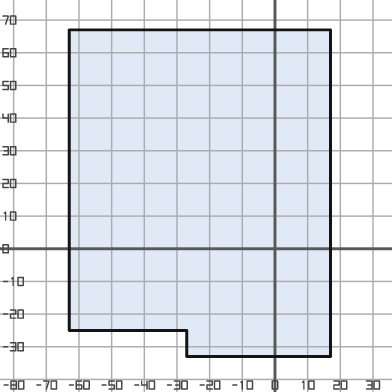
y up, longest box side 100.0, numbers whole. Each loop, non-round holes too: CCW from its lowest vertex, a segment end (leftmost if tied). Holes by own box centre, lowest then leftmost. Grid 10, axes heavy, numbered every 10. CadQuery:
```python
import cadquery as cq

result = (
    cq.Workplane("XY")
    .moveTo(-27.0, -33.0)
    .lineTo(17.0, -33.0)
    .lineTo(17.0, 67.0)
    .lineTo(-63.0, 67.0)
    .lineTo(-63.0, -25.0)
    .lineTo(-27.0, -25.0)
    .close()
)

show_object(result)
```